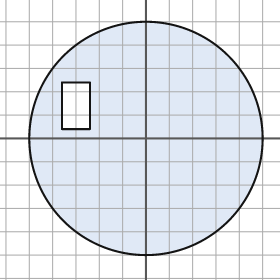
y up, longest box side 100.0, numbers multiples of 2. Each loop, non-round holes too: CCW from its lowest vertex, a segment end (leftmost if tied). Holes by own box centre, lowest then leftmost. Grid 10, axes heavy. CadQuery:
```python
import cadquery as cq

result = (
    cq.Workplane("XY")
    .moveTo(0.0, 0.0)
    .circle(50.0)
    .moveTo(-36.0, 4.0)
    .lineTo(-24.0, 4.0)
    .lineTo(-24.0, 24.0)
    .lineTo(-36.0, 24.0)
    .close()
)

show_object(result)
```